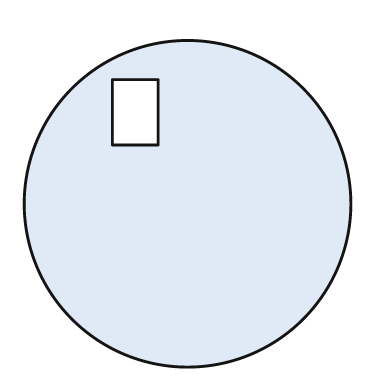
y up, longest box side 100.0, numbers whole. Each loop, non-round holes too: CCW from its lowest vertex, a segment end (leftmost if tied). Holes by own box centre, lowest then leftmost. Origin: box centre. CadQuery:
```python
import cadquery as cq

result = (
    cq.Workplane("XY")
    .moveTo(0.0, 0.0)
    .circle(50.0)
    .moveTo(-23.0, 18.0)
    .lineTo(-9.0, 18.0)
    .lineTo(-9.0, 38.0)
    .lineTo(-23.0, 38.0)
    .close()
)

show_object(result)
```